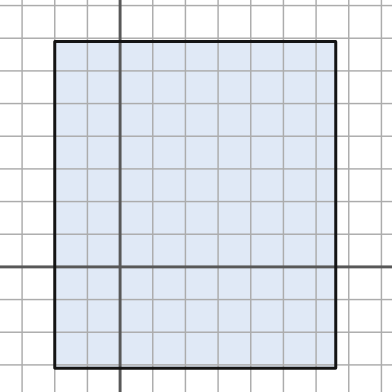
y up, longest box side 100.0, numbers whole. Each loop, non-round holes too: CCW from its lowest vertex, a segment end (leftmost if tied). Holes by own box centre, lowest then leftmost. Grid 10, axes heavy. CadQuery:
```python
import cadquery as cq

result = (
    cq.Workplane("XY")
    .moveTo(-20.0, -31.0)
    .lineTo(66.0, -31.0)
    .lineTo(66.0, 69.0)
    .lineTo(-20.0, 69.0)
    .close()
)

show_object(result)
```